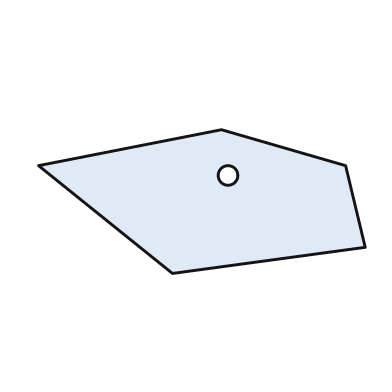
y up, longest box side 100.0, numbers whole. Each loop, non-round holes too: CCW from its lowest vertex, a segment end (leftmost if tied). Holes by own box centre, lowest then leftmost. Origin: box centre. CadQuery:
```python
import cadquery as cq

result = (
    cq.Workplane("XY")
    .moveTo(-9.0, -22.0)
    .lineTo(50.0, -14.0)
    .lineTo(44.0, 11.0)
    .lineTo(6.0, 22.0)
    .lineTo(-50.0, 11.0)
    .close()
    .moveTo(8.0, 8.0)
    .circle(3.0)
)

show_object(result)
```